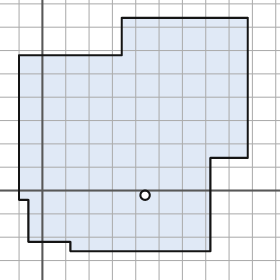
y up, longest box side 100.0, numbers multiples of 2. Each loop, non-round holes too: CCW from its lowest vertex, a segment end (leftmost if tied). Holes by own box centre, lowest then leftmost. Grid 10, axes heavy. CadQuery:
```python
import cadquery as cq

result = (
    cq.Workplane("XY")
    .moveTo(12.0, -26.0)
    .lineTo(72.0, -26.0)
    .lineTo(72.0, 14.0)
    .lineTo(88.0, 14.0)
    .lineTo(88.0, 74.0)
    .lineTo(34.0, 74.0)
    .lineTo(34.0, 58.0)
    .lineTo(-10.0, 58.0)
    .lineTo(-10.0, -4.0)
    .lineTo(-6.0, -4.0)
    .lineTo(-6.0, -22.0)
    .lineTo(12.0, -22.0)
    .close()
    .moveTo(44.0, -2.0)
    .circle(2.0)
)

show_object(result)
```